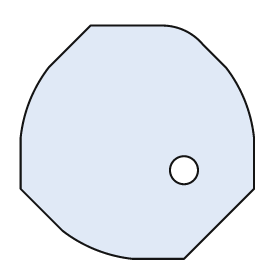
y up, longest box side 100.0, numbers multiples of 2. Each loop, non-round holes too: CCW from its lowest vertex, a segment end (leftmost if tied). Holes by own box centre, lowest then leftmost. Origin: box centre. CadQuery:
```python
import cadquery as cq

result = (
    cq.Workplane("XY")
    .moveTo(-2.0, -50.0)
    .lineTo(20.0, -50.0)
    .lineTo(50.0, -20.0)
    .lineTo(50.0, 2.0)
    .threePointArc((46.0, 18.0), (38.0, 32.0))
    .lineTo(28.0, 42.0)
    .threePointArc((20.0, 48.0), (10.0, 50.0))
    .lineTo(-20.0, 50.0)
    .lineTo(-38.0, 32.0)
    .threePointArc((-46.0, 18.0), (-50.0, 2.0))
    .lineTo(-50.0, -20.0)
    .lineTo(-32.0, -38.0)
    .threePointArc((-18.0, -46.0), (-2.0, -50.0))
    .close()
    .moveTo(20.0, -12.0)
    .circle(6.0)
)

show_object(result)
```